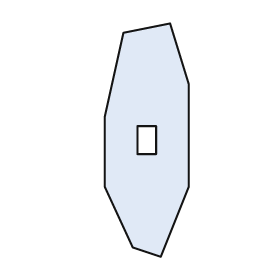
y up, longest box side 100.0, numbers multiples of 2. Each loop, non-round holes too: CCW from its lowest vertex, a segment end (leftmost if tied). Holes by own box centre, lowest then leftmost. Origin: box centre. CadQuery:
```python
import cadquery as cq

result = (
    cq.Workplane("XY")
    .moveTo(6.0, -50.0)
    .lineTo(18.0, -20.0)
    .lineTo(18.0, 24.0)
    .lineTo(10.0, 50.0)
    .lineTo(-10.0, 46.0)
    .lineTo(-18.0, 10.0)
    .lineTo(-18.0, -20.0)
    .lineTo(-6.0, -46.0)
    .close()
    .moveTo(-4.0, -6.0)
    .lineTo(4.0, -6.0)
    .lineTo(4.0, 6.0)
    .lineTo(-4.0, 6.0)
    .close()
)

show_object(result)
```